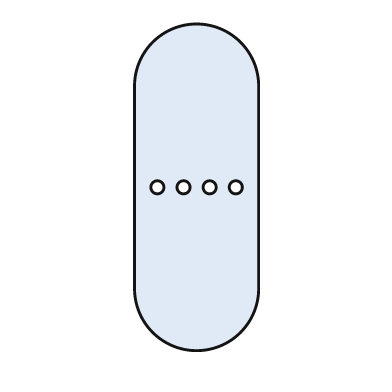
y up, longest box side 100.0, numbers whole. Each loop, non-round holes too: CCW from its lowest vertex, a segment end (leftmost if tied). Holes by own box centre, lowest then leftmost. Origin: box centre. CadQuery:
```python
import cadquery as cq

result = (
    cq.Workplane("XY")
    .moveTo(-19.0, -31.0)
    .threePointArc((0.0, -50.0), (19.0, -31.0))
    .lineTo(19.0, 31.0)
    .threePointArc((0.0, 50.0), (-19.0, 31.0))
    .close()
    .moveTo(-12.0, 0.0)
    .circle(2.0)
    .moveTo(-4.0, 0.0)
    .circle(2.0)
    .moveTo(4.0, 0.0)
    .circle(2.0)
    .moveTo(12.0, 0.0)
    .circle(2.0)
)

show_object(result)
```